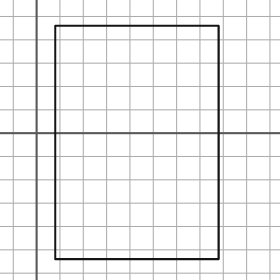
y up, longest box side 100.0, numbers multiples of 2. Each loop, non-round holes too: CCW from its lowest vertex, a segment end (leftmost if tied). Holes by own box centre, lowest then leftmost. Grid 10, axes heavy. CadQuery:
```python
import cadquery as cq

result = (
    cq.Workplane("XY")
    .moveTo(8.0, -54.0)
    .lineTo(78.0, -54.0)
    .lineTo(78.0, 46.0)
    .lineTo(8.0, 46.0)
    .close()
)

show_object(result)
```